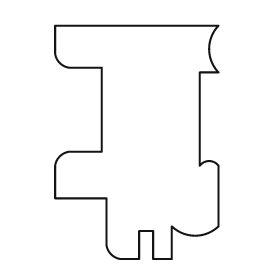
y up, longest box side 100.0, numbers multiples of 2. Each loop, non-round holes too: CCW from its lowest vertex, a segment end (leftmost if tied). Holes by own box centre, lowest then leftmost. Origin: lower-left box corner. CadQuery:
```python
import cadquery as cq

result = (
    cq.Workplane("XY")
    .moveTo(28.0, 0.0)
    .lineTo(36.0, 0.0)
    .lineTo(36.0, 12.0)
    .lineTo(42.0, 12.0)
    .lineTo(42.0, 0.0)
    .lineTo(50.0, 0.0)
    .lineTo(50.0, 14.0)
    .threePointArc((60.0, 10.0), (70.0, 14.0))
    .lineTo(70.0, 40.0)
    .threePointArc((66.0, 42.0), (62.0, 40.0))
    .lineTo(62.0, 80.0)
    .lineTo(70.0, 80.0)
    .threePointArc((66.0, 90.0), (70.0, 100.0))
    .lineTo(0.0, 100.0)
    .lineTo(0.0, 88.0)
    .threePointArc((2.0, 84.0), (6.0, 82.0))
    .lineTo(20.0, 82.0)
    .lineTo(20.0, 46.0)
    .lineTo(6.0, 46.0)
    .threePointArc((2.0, 44.0), (0.0, 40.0))
    .lineTo(0.0, 26.0)
    .lineTo(22.0, 26.0)
    .lineTo(22.0, 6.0)
    .threePointArc((24.0, 2.0), (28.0, 0.0))
    .close()
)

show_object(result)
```